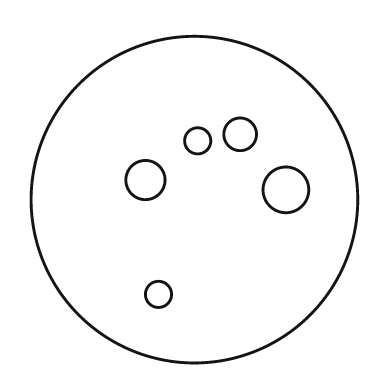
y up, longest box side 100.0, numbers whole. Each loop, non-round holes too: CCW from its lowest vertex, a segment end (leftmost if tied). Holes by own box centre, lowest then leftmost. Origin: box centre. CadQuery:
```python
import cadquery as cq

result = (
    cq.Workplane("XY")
    .moveTo(0.0, 0.0)
    .circle(50.0)
    .moveTo(-11.0, -29.0)
    .circle(4.0)
    .moveTo(28.0, 3.0)
    .circle(7.0)
    .moveTo(-15.0, 6.0)
    .circle(6.0)
    .moveTo(1.0, 18.0)
    .circle(4.0)
    .moveTo(14.0, 20.0)
    .circle(5.0)
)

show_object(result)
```